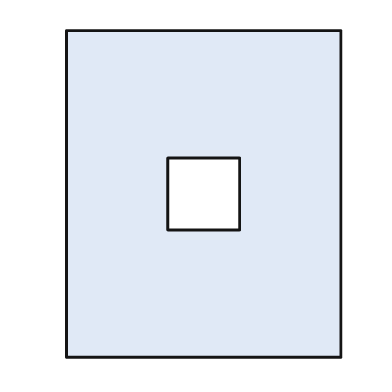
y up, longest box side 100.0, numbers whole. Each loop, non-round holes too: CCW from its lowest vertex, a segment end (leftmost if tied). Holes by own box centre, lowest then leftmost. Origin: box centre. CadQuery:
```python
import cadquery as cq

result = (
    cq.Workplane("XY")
    .moveTo(-42.0, -50.0)
    .lineTo(42.0, -50.0)
    .lineTo(42.0, 50.0)
    .lineTo(-42.0, 50.0)
    .close()
    .moveTo(-11.0, -11.0)
    .lineTo(11.0, -11.0)
    .lineTo(11.0, 11.0)
    .lineTo(-11.0, 11.0)
    .close()
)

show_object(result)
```